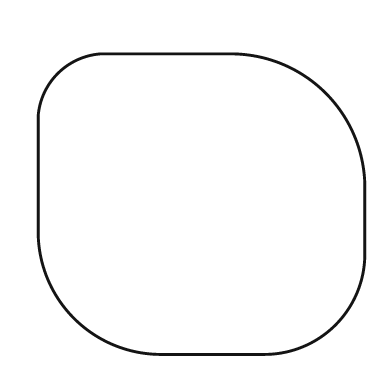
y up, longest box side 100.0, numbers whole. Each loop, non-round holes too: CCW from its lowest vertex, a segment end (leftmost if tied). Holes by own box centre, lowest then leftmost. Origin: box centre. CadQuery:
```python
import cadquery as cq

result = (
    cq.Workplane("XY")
    .moveTo(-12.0, -46.0)
    .lineTo(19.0, -46.0)
    .threePointArc((41.0, -37.0), (50.0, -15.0))
    .lineTo(50.0, 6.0)
    .threePointArc((38.0, 34.0), (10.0, 46.0))
    .lineTo(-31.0, 46.0)
    .threePointArc((-44.0, 40.0), (-50.0, 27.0))
    .lineTo(-50.0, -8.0)
    .threePointArc((-39.0, -35.0), (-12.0, -46.0))
    .close()
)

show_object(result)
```